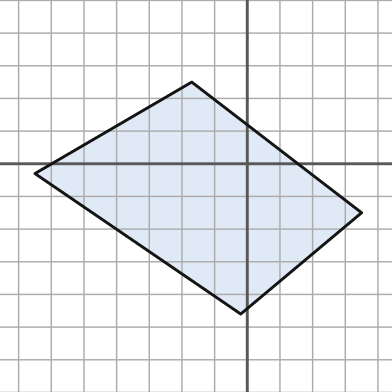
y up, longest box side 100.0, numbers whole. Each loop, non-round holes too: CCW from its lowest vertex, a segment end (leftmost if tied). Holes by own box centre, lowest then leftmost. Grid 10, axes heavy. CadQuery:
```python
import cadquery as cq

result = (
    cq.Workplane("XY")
    .moveTo(-2.0, -46.0)
    .lineTo(35.0, -15.0)
    .lineTo(-17.0, 25.0)
    .lineTo(-65.0, -3.0)
    .close()
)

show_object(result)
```